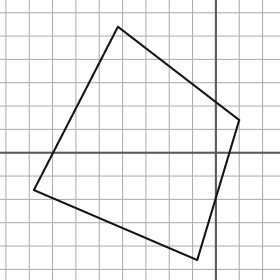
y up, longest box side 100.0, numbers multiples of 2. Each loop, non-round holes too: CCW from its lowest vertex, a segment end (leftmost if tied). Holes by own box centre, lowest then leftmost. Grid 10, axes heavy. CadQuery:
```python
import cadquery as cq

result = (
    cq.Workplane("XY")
    .moveTo(-8.0, -46.0)
    .lineTo(10.0, 14.0)
    .lineTo(-42.0, 54.0)
    .lineTo(-78.0, -16.0)
    .close()
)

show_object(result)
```